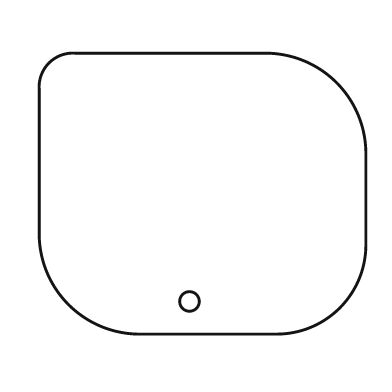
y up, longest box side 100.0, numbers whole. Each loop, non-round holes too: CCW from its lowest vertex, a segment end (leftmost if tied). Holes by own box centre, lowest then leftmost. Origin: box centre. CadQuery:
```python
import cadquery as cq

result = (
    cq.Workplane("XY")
    .moveTo(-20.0, -43.0)
    .lineTo(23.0, -43.0)
    .threePointArc((42.0, -35.0), (50.0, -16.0))
    .lineTo(50.0, 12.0)
    .threePointArc((41.0, 34.0), (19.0, 43.0))
    .lineTo(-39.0, 43.0)
    .threePointArc((-47.0, 40.0), (-50.0, 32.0))
    .lineTo(-50.0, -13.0)
    .threePointArc((-41.0, -34.0), (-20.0, -43.0))
    .close()
    .moveTo(-4.0, -33.0)
    .circle(3.0)
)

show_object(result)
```